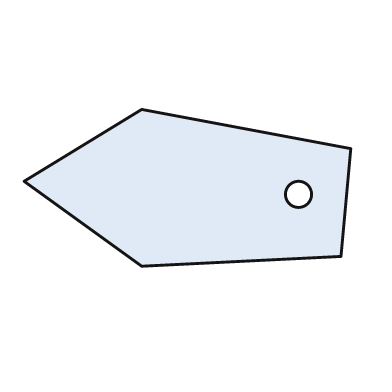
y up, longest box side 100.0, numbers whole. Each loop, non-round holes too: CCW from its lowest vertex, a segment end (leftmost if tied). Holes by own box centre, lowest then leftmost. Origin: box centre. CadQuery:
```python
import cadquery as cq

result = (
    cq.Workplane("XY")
    .moveTo(-14.0, -24.0)
    .lineTo(47.0, -21.0)
    .lineTo(50.0, 12.0)
    .lineTo(-14.0, 24.0)
    .lineTo(-50.0, 2.0)
    .close()
    .moveTo(34.0, -2.0)
    .circle(4.0)
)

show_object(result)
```